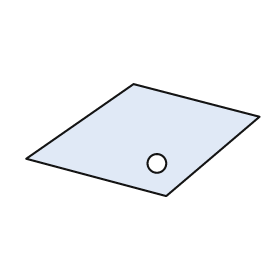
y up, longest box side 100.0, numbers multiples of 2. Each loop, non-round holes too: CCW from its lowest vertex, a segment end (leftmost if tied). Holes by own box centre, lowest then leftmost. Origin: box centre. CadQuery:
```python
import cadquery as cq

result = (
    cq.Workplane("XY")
    .moveTo(10.0, -24.0)
    .lineTo(50.0, 10.0)
    .lineTo(-4.0, 24.0)
    .lineTo(-50.0, -8.0)
    .close()
    .moveTo(6.0, -10.0)
    .circle(4.0)
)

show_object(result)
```